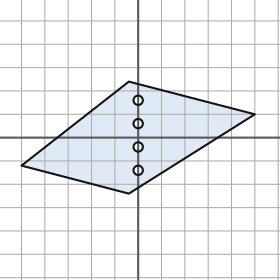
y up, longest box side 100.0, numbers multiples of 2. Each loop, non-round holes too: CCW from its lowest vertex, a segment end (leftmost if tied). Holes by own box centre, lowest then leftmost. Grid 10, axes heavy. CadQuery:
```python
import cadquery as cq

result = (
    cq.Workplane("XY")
    .moveTo(-4.0, -24.0)
    .lineTo(50.0, 10.0)
    .lineTo(-4.0, 24.0)
    .lineTo(-50.0, -12.0)
    .close()
    .moveTo(0.0, -14.0)
    .circle(2.0)
    .moveTo(0.0, -4.0)
    .circle(2.0)
    .moveTo(0.0, 6.0)
    .circle(2.0)
    .moveTo(0.0, 16.0)
    .circle(2.0)
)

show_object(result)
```